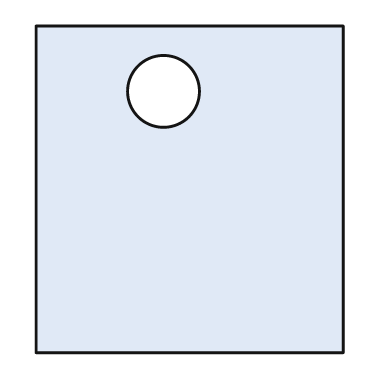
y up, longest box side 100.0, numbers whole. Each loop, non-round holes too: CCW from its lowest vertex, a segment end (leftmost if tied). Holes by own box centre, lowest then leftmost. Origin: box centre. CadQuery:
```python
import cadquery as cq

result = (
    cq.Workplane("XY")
    .moveTo(-47.0, -50.0)
    .lineTo(47.0, -50.0)
    .lineTo(47.0, 50.0)
    .lineTo(-47.0, 50.0)
    .close()
    .moveTo(-8.0, 30.0)
    .circle(11.0)
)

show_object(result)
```